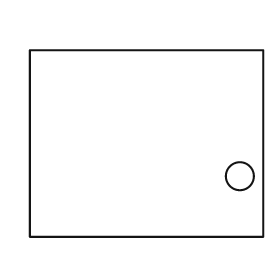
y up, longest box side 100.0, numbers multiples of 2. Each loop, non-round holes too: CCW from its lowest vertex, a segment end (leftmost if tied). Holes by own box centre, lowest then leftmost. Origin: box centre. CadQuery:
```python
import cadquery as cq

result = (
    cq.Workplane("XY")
    .moveTo(-50.0, -40.0)
    .lineTo(50.0, -40.0)
    .lineTo(50.0, 40.0)
    .lineTo(-50.0, 40.0)
    .close()
    .moveTo(40.0, -14.0)
    .circle(6.0)
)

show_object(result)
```